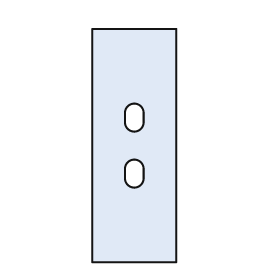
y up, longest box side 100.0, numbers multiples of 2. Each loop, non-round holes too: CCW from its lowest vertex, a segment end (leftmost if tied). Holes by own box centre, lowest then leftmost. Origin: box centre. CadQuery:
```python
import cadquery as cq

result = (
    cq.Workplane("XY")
    .moveTo(-18.0, -50.0)
    .lineTo(18.0, -50.0)
    .lineTo(18.0, 50.0)
    .lineTo(-18.0, 50.0)
    .close()
    .moveTo(-4.0, -14.0)
    .threePointArc((0.0, -18.0), (4.0, -14.0))
    .lineTo(4.0, -10.0)
    .threePointArc((0.0, -6.0), (-4.0, -10.0))
    .close()
    .moveTo(-4.0, 10.0)
    .threePointArc((0.0, 6.0), (4.0, 10.0))
    .lineTo(4.0, 14.0)
    .threePointArc((0.0, 18.0), (-4.0, 14.0))
    .close()
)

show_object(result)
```